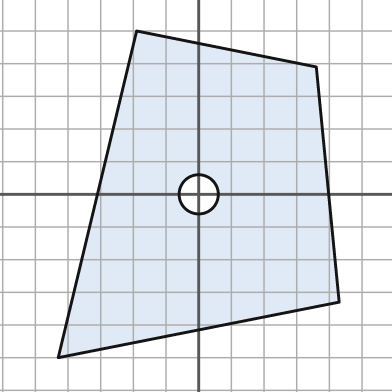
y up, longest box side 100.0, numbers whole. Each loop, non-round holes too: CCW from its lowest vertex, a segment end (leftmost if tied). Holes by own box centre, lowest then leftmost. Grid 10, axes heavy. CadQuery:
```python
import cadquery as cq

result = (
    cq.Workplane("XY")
    .moveTo(-43.0, -50.0)
    .lineTo(43.0, -33.0)
    .lineTo(36.0, 39.0)
    .lineTo(-19.0, 50.0)
    .close()
    .moveTo(0.0, 0.0)
    .circle(6.0)
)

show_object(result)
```